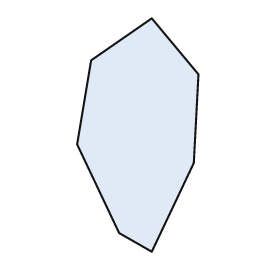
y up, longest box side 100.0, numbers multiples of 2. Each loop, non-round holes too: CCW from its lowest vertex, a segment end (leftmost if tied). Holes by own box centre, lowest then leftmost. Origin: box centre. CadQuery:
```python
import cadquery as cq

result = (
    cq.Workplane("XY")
    .moveTo(6.0, -50.0)
    .lineTo(24.0, -12.0)
    .lineTo(26.0, 26.0)
    .lineTo(6.0, 50.0)
    .lineTo(-20.0, 32.0)
    .lineTo(-26.0, -4.0)
    .lineTo(-8.0, -42.0)
    .close()
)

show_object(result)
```